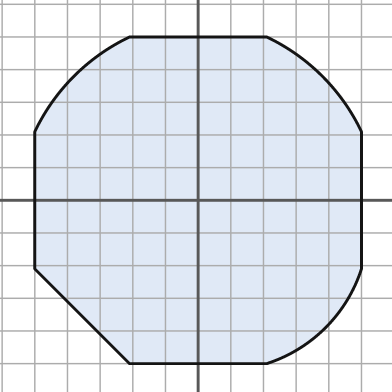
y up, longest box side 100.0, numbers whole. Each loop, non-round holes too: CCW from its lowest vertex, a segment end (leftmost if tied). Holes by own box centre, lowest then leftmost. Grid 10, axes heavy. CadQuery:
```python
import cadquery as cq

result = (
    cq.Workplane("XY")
    .moveTo(-21.0, -50.0)
    .lineTo(21.0, -50.0)
    .threePointArc((39.0, -39.0), (50.0, -21.0))
    .lineTo(50.0, 21.0)
    .threePointArc((38.0, 38.0), (21.0, 50.0))
    .lineTo(-21.0, 50.0)
    .threePointArc((-38.0, 38.0), (-50.0, 21.0))
    .lineTo(-50.0, -21.0)
    .close()
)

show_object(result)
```